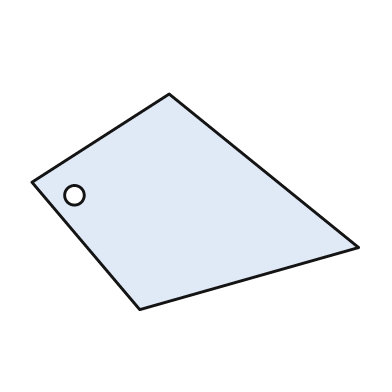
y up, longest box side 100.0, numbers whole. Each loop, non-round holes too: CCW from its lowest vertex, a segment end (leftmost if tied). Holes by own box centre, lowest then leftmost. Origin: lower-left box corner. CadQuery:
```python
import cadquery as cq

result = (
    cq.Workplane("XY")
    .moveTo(33.0, 0.0)
    .lineTo(100.0, 19.0)
    .lineTo(42.0, 66.0)
    .lineTo(0.0, 39.0)
    .close()
    .moveTo(13.0, 35.0)
    .circle(3.0)
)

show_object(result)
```